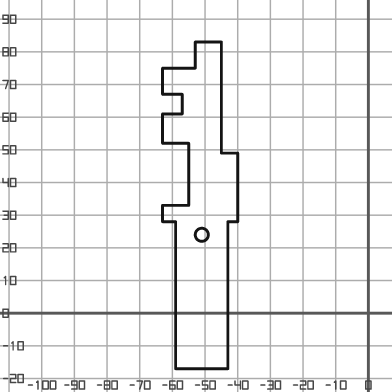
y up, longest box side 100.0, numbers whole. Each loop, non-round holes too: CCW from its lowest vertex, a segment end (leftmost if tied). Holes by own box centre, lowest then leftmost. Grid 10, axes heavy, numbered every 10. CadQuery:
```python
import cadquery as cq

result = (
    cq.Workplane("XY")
    .moveTo(-59.0, -17.0)
    .lineTo(-43.0, -17.0)
    .lineTo(-43.0, 28.0)
    .lineTo(-40.0, 28.0)
    .lineTo(-40.0, 49.0)
    .lineTo(-45.0, 49.0)
    .lineTo(-45.0, 83.0)
    .lineTo(-53.0, 83.0)
    .lineTo(-53.0, 75.0)
    .lineTo(-63.0, 75.0)
    .lineTo(-63.0, 67.0)
    .lineTo(-57.0, 67.0)
    .lineTo(-57.0, 61.0)
    .lineTo(-63.0, 61.0)
    .lineTo(-63.0, 52.0)
    .lineTo(-55.0, 52.0)
    .lineTo(-55.0, 33.0)
    .lineTo(-63.0, 33.0)
    .lineTo(-63.0, 28.0)
    .lineTo(-59.0, 28.0)
    .close()
    .moveTo(-51.0, 24.0)
    .circle(2.0)
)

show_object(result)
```